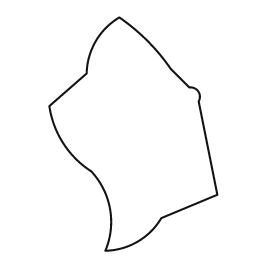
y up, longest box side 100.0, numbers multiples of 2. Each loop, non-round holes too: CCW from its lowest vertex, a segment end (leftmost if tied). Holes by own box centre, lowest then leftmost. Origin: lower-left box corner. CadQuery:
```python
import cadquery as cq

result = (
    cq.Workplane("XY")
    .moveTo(24.0, 0.0)
    .threePointArc((38.0, 4.0), (48.0, 14.0))
    .lineTo(72.0, 24.0)
    .lineTo(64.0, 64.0)
    .threePointArc((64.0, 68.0), (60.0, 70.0))
    .lineTo(52.0, 78.0)
    .threePointArc((42.0, 90.0), (30.0, 100.0))
    .threePointArc((20.0, 90.0), (16.0, 76.0))
    .lineTo(0.0, 62.0)
    .threePointArc((6.0, 46.0), (18.0, 34.0))
    .threePointArc((26.0, 18.0), (24.0, 0.0))
    .close()
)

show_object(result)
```